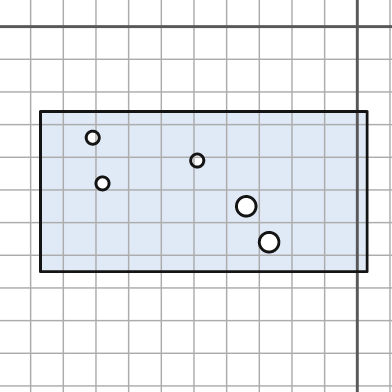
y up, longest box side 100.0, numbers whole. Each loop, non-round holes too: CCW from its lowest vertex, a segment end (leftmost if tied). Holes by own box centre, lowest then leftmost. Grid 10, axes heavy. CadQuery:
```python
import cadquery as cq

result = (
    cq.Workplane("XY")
    .moveTo(-97.0, -75.0)
    .lineTo(3.0, -75.0)
    .lineTo(3.0, -26.0)
    .lineTo(-97.0, -26.0)
    .close()
    .moveTo(-27.0, -66.0)
    .circle(3.0)
    .moveTo(-34.0, -55.0)
    .circle(3.0)
    .moveTo(-78.0, -48.0)
    .circle(2.0)
    .moveTo(-49.0, -41.0)
    .circle(2.0)
    .moveTo(-81.0, -34.0)
    .circle(2.0)
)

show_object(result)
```